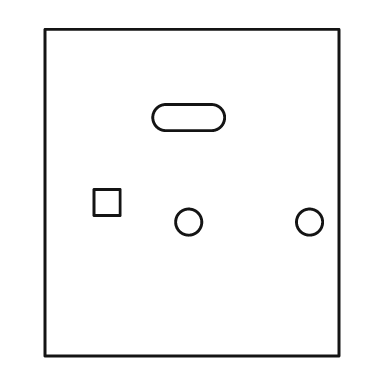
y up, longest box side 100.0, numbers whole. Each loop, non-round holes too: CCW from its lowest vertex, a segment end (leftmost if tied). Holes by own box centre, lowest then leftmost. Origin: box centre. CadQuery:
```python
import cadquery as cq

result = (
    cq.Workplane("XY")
    .moveTo(-45.0, -50.0)
    .lineTo(45.0, -50.0)
    .lineTo(45.0, 50.0)
    .lineTo(-45.0, 50.0)
    .close()
    .moveTo(-1.0, -9.0)
    .circle(4.0)
    .moveTo(36.0, -9.0)
    .circle(4.0)
    .moveTo(-30.0, -7.0)
    .lineTo(-22.0, -7.0)
    .lineTo(-22.0, 1.0)
    .lineTo(-30.0, 1.0)
    .close()
    .moveTo(-8.0, 19.0)
    .lineTo(6.0, 19.0)
    .threePointArc((10.0, 23.0), (6.0, 27.0))
    .lineTo(-8.0, 27.0)
    .threePointArc((-12.0, 23.0), (-8.0, 19.0))
    .close()
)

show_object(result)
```